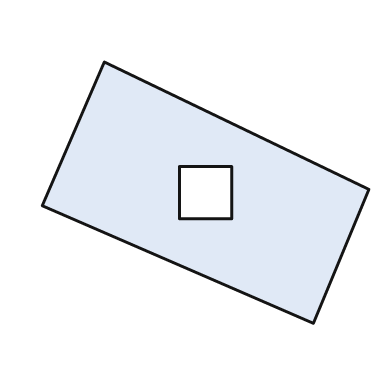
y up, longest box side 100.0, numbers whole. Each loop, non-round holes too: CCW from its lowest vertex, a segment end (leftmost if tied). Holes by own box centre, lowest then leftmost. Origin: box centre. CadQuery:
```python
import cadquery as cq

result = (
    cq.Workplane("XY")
    .moveTo(33.0, -40.0)
    .lineTo(50.0, 1.0)
    .lineTo(-31.0, 40.0)
    .lineTo(-50.0, -4.0)
    .close()
    .moveTo(-8.0, -8.0)
    .lineTo(8.0, -8.0)
    .lineTo(8.0, 8.0)
    .lineTo(-8.0, 8.0)
    .close()
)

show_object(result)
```